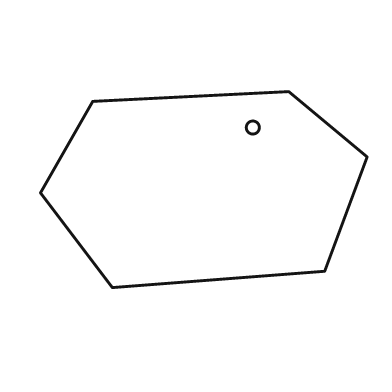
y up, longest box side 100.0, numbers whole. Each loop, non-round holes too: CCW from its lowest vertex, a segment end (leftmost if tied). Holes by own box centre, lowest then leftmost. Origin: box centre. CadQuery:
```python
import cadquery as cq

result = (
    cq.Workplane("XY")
    .moveTo(-28.0, -30.0)
    .lineTo(37.0, -25.0)
    .lineTo(50.0, 10.0)
    .lineTo(26.0, 30.0)
    .lineTo(-34.0, 27.0)
    .lineTo(-50.0, -1.0)
    .close()
    .moveTo(15.0, 19.0)
    .circle(2.0)
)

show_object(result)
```